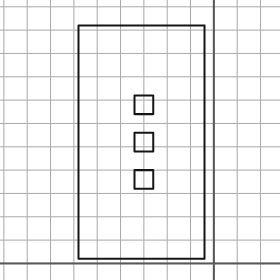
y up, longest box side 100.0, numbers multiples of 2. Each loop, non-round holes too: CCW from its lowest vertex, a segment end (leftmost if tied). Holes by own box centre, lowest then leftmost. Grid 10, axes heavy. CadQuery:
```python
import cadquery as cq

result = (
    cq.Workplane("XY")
    .moveTo(-58.0, 2.0)
    .lineTo(-4.0, 2.0)
    .lineTo(-4.0, 102.0)
    .lineTo(-58.0, 102.0)
    .close()
    .moveTo(-34.0, 32.0)
    .lineTo(-26.0, 32.0)
    .lineTo(-26.0, 40.0)
    .lineTo(-34.0, 40.0)
    .close()
    .moveTo(-34.0, 48.0)
    .lineTo(-26.0, 48.0)
    .lineTo(-26.0, 56.0)
    .lineTo(-34.0, 56.0)
    .close()
    .moveTo(-34.0, 64.0)
    .lineTo(-26.0, 64.0)
    .lineTo(-26.0, 72.0)
    .lineTo(-34.0, 72.0)
    .close()
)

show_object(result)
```